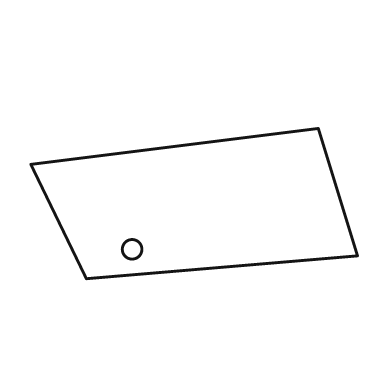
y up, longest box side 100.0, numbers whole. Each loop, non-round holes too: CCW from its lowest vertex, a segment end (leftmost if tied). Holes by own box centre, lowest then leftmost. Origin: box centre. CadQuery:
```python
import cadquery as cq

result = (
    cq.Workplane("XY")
    .moveTo(-33.0, -23.0)
    .lineTo(50.0, -16.0)
    .lineTo(38.0, 23.0)
    .lineTo(-50.0, 12.0)
    .close()
    .moveTo(-19.0, -14.0)
    .circle(3.0)
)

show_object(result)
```